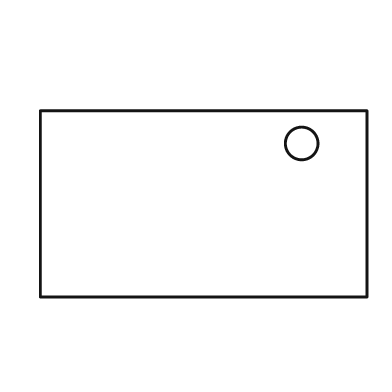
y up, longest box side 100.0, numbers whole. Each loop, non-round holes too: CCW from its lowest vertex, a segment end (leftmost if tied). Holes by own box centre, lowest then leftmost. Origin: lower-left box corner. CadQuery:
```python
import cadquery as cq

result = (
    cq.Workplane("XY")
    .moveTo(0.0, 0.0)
    .lineTo(100.0, 0.0)
    .lineTo(100.0, 57.0)
    .lineTo(0.0, 57.0)
    .close()
    .moveTo(80.0, 47.0)
    .circle(5.0)
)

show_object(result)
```